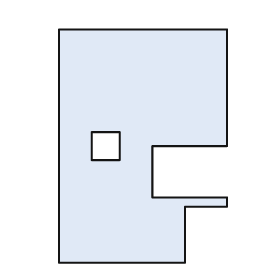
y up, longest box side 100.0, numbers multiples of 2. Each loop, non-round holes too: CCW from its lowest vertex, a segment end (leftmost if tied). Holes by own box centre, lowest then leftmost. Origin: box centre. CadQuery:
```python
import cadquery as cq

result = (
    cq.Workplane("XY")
    .moveTo(-36.0, -50.0)
    .lineTo(18.0, -50.0)
    .lineTo(18.0, -26.0)
    .lineTo(36.0, -26.0)
    .lineTo(36.0, -22.0)
    .lineTo(4.0, -22.0)
    .lineTo(4.0, 0.0)
    .lineTo(36.0, 0.0)
    .lineTo(36.0, 50.0)
    .lineTo(-36.0, 50.0)
    .close()
    .moveTo(-22.0, -6.0)
    .lineTo(-10.0, -6.0)
    .lineTo(-10.0, 6.0)
    .lineTo(-22.0, 6.0)
    .close()
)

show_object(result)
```